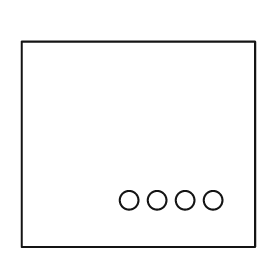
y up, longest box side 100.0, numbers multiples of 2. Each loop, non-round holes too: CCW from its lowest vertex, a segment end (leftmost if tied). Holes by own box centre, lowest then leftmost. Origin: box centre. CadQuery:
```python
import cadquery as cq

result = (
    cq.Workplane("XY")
    .moveTo(-50.0, -44.0)
    .lineTo(50.0, -44.0)
    .lineTo(50.0, 44.0)
    .lineTo(-50.0, 44.0)
    .close()
    .moveTo(-4.0, -24.0)
    .circle(4.0)
    .moveTo(8.0, -24.0)
    .circle(4.0)
    .moveTo(20.0, -24.0)
    .circle(4.0)
    .moveTo(32.0, -24.0)
    .circle(4.0)
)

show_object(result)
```